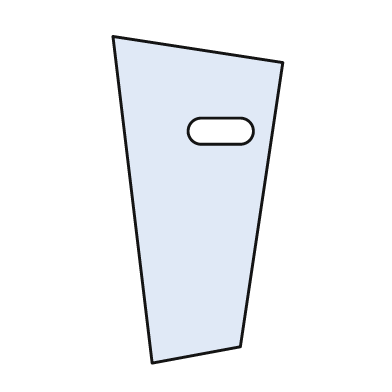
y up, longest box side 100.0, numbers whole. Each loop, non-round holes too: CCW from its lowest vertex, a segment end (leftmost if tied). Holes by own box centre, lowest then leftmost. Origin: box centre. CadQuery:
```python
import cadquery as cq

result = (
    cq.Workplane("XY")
    .moveTo(-14.0, -50.0)
    .lineTo(13.0, -45.0)
    .lineTo(26.0, 42.0)
    .lineTo(-26.0, 50.0)
    .close()
    .moveTo(1.0, 17.0)
    .lineTo(13.0, 17.0)
    .threePointArc((17.0, 21.0), (13.0, 25.0))
    .lineTo(1.0, 25.0)
    .threePointArc((-3.0, 21.0), (1.0, 17.0))
    .close()
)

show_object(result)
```